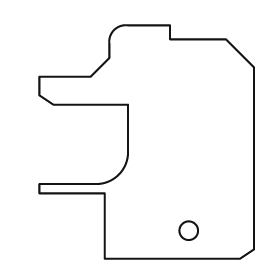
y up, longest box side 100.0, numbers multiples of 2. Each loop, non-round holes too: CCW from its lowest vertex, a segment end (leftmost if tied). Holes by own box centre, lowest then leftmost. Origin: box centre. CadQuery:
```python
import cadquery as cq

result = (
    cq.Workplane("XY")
    .moveTo(-18.0, -50.0)
    .lineTo(40.0, -50.0)
    .lineTo(46.0, -46.0)
    .lineTo(46.0, 32.0)
    .lineTo(34.0, 44.0)
    .lineTo(10.0, 44.0)
    .lineTo(10.0, 50.0)
    .lineTo(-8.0, 50.0)
    .threePointArc((-14.0, 48.0), (-16.0, 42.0))
    .lineTo(-16.0, 36.0)
    .lineTo(-24.0, 28.0)
    .lineTo(-46.0, 28.0)
    .lineTo(-46.0, 20.0)
    .lineTo(-40.0, 16.0)
    .lineTo(-8.0, 16.0)
    .lineTo(-8.0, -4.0)
    .threePointArc((-12.0, -14.0), (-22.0, -18.0))
    .lineTo(-46.0, -18.0)
    .lineTo(-46.0, -22.0)
    .lineTo(-18.0, -22.0)
    .close()
    .moveTo(18.0, -38.0)
    .circle(4.0)
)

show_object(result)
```